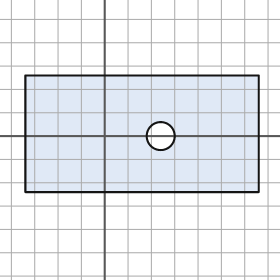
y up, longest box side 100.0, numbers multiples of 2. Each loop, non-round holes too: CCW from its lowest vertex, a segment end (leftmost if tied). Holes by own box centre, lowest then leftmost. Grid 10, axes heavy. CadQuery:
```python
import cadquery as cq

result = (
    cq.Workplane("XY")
    .moveTo(-34.0, -24.0)
    .lineTo(66.0, -24.0)
    .lineTo(66.0, 26.0)
    .lineTo(-34.0, 26.0)
    .close()
    .moveTo(24.0, 0.0)
    .circle(6.0)
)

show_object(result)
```